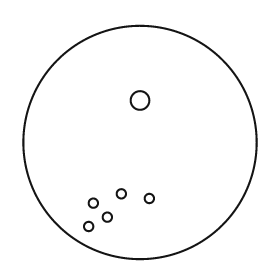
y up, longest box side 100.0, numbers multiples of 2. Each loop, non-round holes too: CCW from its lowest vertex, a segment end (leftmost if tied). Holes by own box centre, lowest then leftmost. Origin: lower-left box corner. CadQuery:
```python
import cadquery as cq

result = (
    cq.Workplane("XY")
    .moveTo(50.0, 50.0)
    .circle(50.0)
    .moveTo(28.0, 14.0)
    .circle(2.0)
    .moveTo(36.0, 18.0)
    .circle(2.0)
    .moveTo(30.0, 24.0)
    .circle(2.0)
    .moveTo(54.0, 26.0)
    .circle(2.0)
    .moveTo(42.0, 28.0)
    .circle(2.0)
    .moveTo(50.0, 68.0)
    .circle(4.0)
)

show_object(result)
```